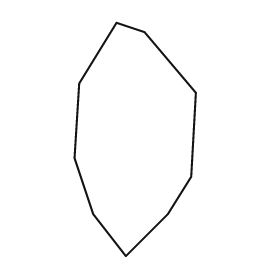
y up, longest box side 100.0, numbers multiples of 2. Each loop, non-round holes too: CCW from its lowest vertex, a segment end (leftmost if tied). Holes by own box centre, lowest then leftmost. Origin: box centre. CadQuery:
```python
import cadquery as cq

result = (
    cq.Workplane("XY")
    .moveTo(-4.0, -50.0)
    .lineTo(14.0, -32.0)
    .lineTo(24.0, -16.0)
    .lineTo(26.0, 20.0)
    .lineTo(4.0, 46.0)
    .lineTo(-8.0, 50.0)
    .lineTo(-24.0, 24.0)
    .lineTo(-26.0, -8.0)
    .lineTo(-18.0, -32.0)
    .close()
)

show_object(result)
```